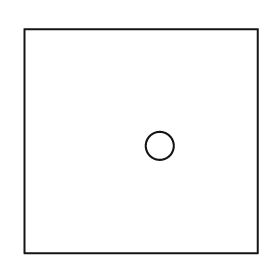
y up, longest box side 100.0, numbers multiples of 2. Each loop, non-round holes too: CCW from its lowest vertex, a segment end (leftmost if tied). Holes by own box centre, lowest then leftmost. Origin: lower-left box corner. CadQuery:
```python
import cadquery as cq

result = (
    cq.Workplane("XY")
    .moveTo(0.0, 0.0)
    .lineTo(100.0, 0.0)
    .lineTo(100.0, 96.0)
    .lineTo(0.0, 96.0)
    .close()
    .moveTo(58.0, 46.0)
    .circle(6.0)
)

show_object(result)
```